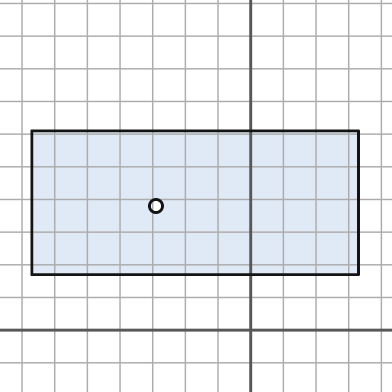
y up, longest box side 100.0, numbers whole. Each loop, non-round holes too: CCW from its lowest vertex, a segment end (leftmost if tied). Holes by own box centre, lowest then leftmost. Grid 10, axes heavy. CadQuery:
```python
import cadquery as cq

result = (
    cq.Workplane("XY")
    .moveTo(-67.0, 17.0)
    .lineTo(33.0, 17.0)
    .lineTo(33.0, 61.0)
    .lineTo(-67.0, 61.0)
    .close()
    .moveTo(-29.0, 38.0)
    .circle(2.0)
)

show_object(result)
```